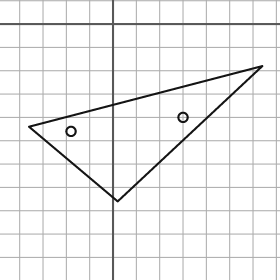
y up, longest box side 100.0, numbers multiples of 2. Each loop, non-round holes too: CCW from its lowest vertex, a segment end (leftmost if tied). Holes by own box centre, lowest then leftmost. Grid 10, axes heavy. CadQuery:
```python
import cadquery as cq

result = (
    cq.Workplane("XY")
    .moveTo(2.0, -76.0)
    .lineTo(64.0, -18.0)
    .lineTo(-36.0, -44.0)
    .close()
    .moveTo(-18.0, -46.0)
    .circle(2.0)
    .moveTo(30.0, -40.0)
    .circle(2.0)
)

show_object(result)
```